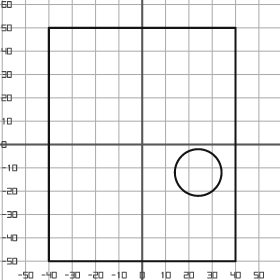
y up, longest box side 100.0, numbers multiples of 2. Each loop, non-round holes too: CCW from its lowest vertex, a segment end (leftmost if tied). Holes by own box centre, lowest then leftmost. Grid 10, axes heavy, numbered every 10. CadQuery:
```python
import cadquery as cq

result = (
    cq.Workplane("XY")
    .moveTo(-40.0, -50.0)
    .lineTo(40.0, -50.0)
    .lineTo(40.0, 50.0)
    .lineTo(-40.0, 50.0)
    .close()
    .moveTo(24.0, -12.0)
    .circle(10.0)
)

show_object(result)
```